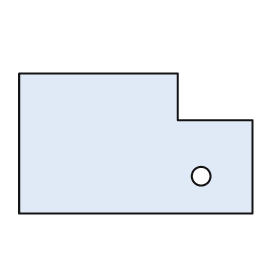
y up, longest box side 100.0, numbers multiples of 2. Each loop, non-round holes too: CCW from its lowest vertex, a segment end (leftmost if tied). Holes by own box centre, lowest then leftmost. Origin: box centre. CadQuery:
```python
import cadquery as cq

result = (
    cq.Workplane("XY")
    .moveTo(-50.0, -30.0)
    .lineTo(50.0, -30.0)
    .lineTo(50.0, 10.0)
    .lineTo(18.0, 10.0)
    .lineTo(18.0, 30.0)
    .lineTo(-50.0, 30.0)
    .close()
    .moveTo(28.0, -14.0)
    .circle(4.0)
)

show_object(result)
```